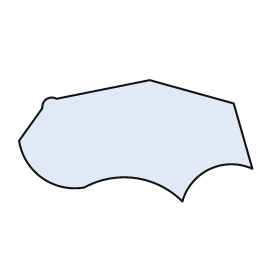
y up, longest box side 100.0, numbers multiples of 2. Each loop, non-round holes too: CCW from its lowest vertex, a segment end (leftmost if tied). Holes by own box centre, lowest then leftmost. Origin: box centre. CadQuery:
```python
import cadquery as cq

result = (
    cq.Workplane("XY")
    .moveTo(20.0, -26.0)
    .threePointArc((32.0, -12.0), (50.0, -12.0))
    .lineTo(42.0, 16.0)
    .lineTo(6.0, 26.0)
    .lineTo(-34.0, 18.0)
    .threePointArc((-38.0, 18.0), (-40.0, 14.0))
    .lineTo(-50.0, 0.0)
    .threePointArc((-40.0, -16.0), (-22.0, -20.0))
    .threePointArc((0.0, -16.0), (20.0, -26.0))
    .close()
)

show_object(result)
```